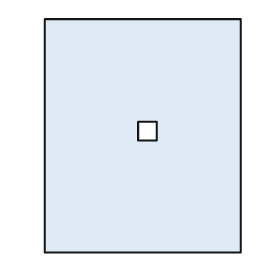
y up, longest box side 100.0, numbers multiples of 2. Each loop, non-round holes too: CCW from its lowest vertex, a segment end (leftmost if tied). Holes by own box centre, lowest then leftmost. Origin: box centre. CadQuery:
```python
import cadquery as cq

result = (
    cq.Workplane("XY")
    .moveTo(-42.0, -50.0)
    .lineTo(42.0, -50.0)
    .lineTo(42.0, 50.0)
    .lineTo(-42.0, 50.0)
    .close()
    .moveTo(-2.0, -2.0)
    .lineTo(6.0, -2.0)
    .lineTo(6.0, 6.0)
    .lineTo(-2.0, 6.0)
    .close()
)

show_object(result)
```